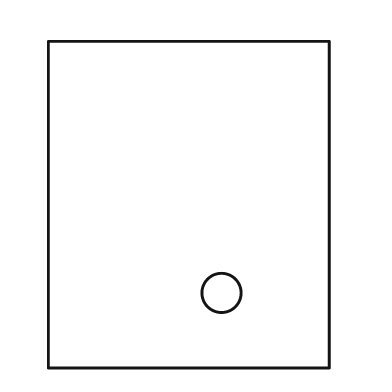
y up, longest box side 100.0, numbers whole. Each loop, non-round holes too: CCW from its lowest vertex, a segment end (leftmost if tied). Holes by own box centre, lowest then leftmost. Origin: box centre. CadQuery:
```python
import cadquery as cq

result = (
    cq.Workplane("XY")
    .moveTo(-43.0, -50.0)
    .lineTo(43.0, -50.0)
    .lineTo(43.0, 50.0)
    .lineTo(-43.0, 50.0)
    .close()
    .moveTo(10.0, -27.0)
    .circle(6.0)
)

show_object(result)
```